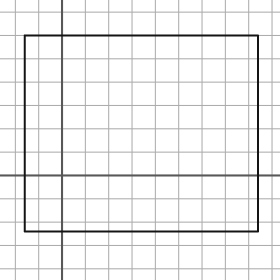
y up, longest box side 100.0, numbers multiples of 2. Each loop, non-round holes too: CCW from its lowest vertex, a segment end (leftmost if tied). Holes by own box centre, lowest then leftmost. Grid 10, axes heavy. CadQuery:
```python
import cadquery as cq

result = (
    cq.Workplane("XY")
    .moveTo(-16.0, -24.0)
    .lineTo(84.0, -24.0)
    .lineTo(84.0, 60.0)
    .lineTo(-16.0, 60.0)
    .close()
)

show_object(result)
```